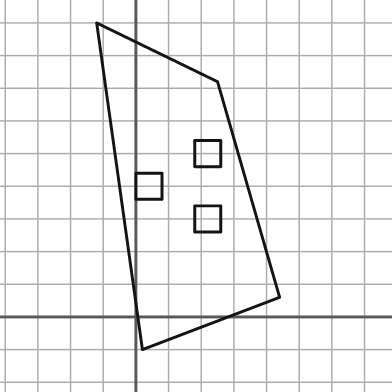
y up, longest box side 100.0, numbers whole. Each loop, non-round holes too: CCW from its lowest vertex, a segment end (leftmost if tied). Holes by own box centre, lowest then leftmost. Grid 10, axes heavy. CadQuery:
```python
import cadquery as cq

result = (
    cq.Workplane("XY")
    .moveTo(2.0, -10.0)
    .lineTo(44.0, 6.0)
    .lineTo(25.0, 72.0)
    .lineTo(-12.0, 90.0)
    .close()
    .moveTo(18.0, 26.0)
    .lineTo(26.0, 26.0)
    .lineTo(26.0, 34.0)
    .lineTo(18.0, 34.0)
    .close()
    .moveTo(0.0, 36.0)
    .lineTo(8.0, 36.0)
    .lineTo(8.0, 44.0)
    .lineTo(0.0, 44.0)
    .close()
    .moveTo(18.0, 46.0)
    .lineTo(26.0, 46.0)
    .lineTo(26.0, 54.0)
    .lineTo(18.0, 54.0)
    .close()
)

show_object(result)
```